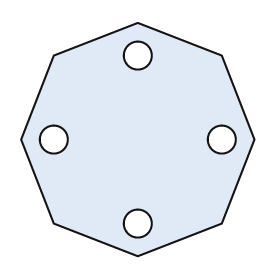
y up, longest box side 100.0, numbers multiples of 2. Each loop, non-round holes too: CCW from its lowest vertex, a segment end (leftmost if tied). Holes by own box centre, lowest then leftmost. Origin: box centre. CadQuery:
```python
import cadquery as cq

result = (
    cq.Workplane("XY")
    .moveTo(0.0, -50.0)
    .lineTo(36.0, -36.0)
    .lineTo(50.0, 0.0)
    .lineTo(36.0, 36.0)
    .lineTo(0.0, 50.0)
    .lineTo(-36.0, 36.0)
    .lineTo(-50.0, 0.0)
    .lineTo(-36.0, -36.0)
    .close()
    .moveTo(0.0, -36.0)
    .circle(6.0)
    .moveTo(-36.0, 0.0)
    .circle(6.0)
    .moveTo(36.0, 0.0)
    .circle(6.0)
    .moveTo(0.0, 36.0)
    .circle(6.0)
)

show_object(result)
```